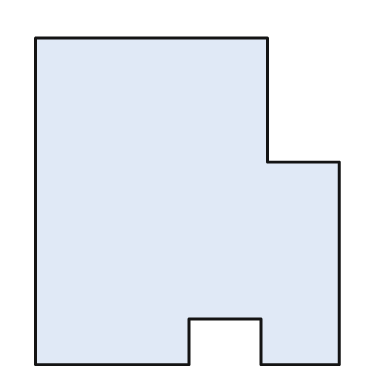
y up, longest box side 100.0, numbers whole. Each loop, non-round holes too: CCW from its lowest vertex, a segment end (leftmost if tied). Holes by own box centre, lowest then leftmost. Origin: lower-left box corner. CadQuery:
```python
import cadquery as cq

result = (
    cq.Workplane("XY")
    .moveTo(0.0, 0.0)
    .lineTo(47.0, 0.0)
    .lineTo(47.0, 14.0)
    .lineTo(69.0, 14.0)
    .lineTo(69.0, 0.0)
    .lineTo(93.0, 0.0)
    .lineTo(93.0, 62.0)
    .lineTo(71.0, 62.0)
    .lineTo(71.0, 100.0)
    .lineTo(0.0, 100.0)
    .close()
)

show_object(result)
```